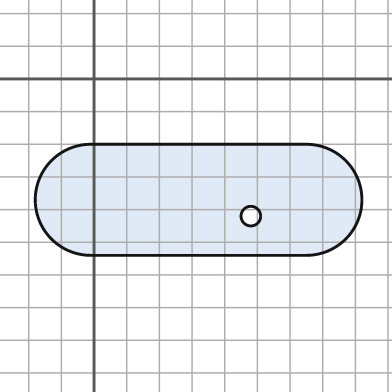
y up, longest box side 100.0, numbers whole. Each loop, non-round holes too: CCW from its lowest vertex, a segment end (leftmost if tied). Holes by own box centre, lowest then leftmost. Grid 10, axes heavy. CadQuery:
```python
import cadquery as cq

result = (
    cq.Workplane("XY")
    .moveTo(-1.0, -54.0)
    .lineTo(65.0, -54.0)
    .threePointArc((82.0, -37.0), (65.0, -20.0))
    .lineTo(-1.0, -20.0)
    .threePointArc((-18.0, -37.0), (-1.0, -54.0))
    .close()
    .moveTo(48.0, -42.0)
    .circle(3.0)
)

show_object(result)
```